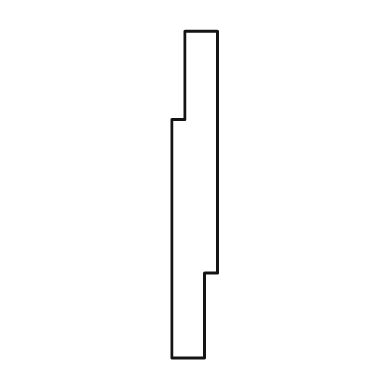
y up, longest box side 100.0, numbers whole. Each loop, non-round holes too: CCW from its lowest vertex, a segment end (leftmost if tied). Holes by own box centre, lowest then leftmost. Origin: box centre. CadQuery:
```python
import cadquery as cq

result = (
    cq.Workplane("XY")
    .moveTo(-7.0, -50.0)
    .lineTo(3.0, -50.0)
    .lineTo(3.0, -24.0)
    .lineTo(7.0, -24.0)
    .lineTo(7.0, 50.0)
    .lineTo(-3.0, 50.0)
    .lineTo(-3.0, 23.0)
    .lineTo(-7.0, 23.0)
    .close()
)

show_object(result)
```